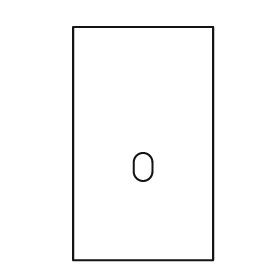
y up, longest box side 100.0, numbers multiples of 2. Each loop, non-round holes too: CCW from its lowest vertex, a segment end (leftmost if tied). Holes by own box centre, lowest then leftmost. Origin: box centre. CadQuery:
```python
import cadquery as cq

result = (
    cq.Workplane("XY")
    .moveTo(-30.0, -50.0)
    .lineTo(30.0, -50.0)
    .lineTo(30.0, 50.0)
    .lineTo(-30.0, 50.0)
    .close()
    .moveTo(-4.0, -12.0)
    .threePointArc((0.0, -16.0), (4.0, -12.0))
    .lineTo(4.0, -8.0)
    .threePointArc((0.0, -4.0), (-4.0, -8.0))
    .close()
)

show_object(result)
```